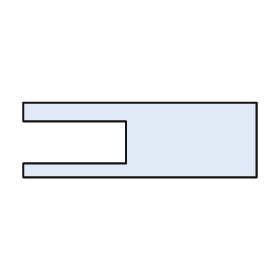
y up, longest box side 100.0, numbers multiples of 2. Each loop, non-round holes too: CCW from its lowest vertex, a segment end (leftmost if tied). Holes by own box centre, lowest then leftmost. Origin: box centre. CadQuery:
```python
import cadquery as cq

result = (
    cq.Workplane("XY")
    .moveTo(-50.0, -16.0)
    .lineTo(50.0, -16.0)
    .lineTo(50.0, 16.0)
    .lineTo(-50.0, 16.0)
    .lineTo(-50.0, 8.0)
    .lineTo(-6.0, 8.0)
    .lineTo(-6.0, -10.0)
    .lineTo(-50.0, -10.0)
    .close()
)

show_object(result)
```